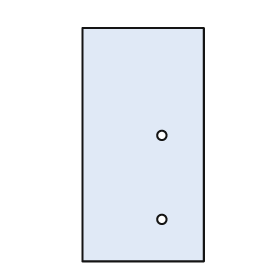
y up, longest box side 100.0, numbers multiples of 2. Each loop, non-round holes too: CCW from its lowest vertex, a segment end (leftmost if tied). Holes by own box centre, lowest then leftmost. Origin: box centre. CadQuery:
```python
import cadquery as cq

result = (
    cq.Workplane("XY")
    .moveTo(-26.0, -50.0)
    .lineTo(26.0, -50.0)
    .lineTo(26.0, 50.0)
    .lineTo(-26.0, 50.0)
    .close()
    .moveTo(8.0, -32.0)
    .circle(2.0)
    .moveTo(8.0, 4.0)
    .circle(2.0)
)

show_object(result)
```